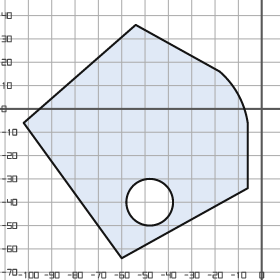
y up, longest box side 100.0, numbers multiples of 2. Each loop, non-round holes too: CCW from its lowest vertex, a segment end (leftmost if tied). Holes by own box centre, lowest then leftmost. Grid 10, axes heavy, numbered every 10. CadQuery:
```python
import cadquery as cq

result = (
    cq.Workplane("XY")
    .moveTo(-60.0, -64.0)
    .lineTo(-6.0, -34.0)
    .lineTo(-6.0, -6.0)
    .threePointArc((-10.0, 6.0), (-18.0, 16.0))
    .lineTo(-54.0, 36.0)
    .lineTo(-102.0, -6.0)
    .close()
    .moveTo(-48.0, -40.0)
    .circle(10.0)
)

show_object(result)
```